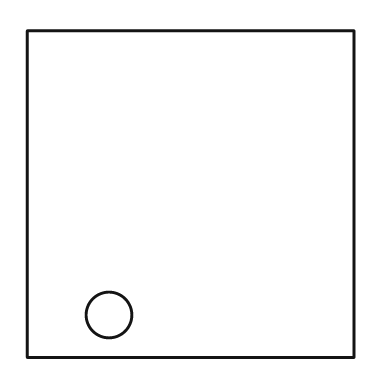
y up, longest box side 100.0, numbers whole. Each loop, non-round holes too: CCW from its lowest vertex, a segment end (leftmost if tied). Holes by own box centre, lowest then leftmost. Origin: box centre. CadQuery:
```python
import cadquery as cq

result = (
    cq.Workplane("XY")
    .moveTo(-50.0, -50.0)
    .lineTo(50.0, -50.0)
    .lineTo(50.0, 50.0)
    .lineTo(-50.0, 50.0)
    .close()
    .moveTo(-25.0, -37.0)
    .circle(7.0)
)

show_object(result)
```